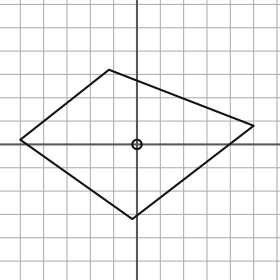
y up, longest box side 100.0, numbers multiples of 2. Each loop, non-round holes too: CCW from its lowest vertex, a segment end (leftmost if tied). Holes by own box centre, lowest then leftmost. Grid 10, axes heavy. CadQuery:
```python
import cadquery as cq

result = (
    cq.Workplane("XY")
    .moveTo(-2.0, -32.0)
    .lineTo(50.0, 8.0)
    .lineTo(-12.0, 32.0)
    .lineTo(-50.0, 2.0)
    .close()
    .moveTo(0.0, 0.0)
    .circle(2.0)
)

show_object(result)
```